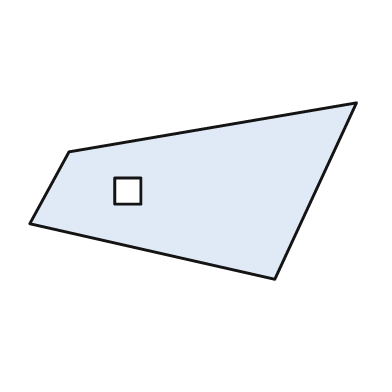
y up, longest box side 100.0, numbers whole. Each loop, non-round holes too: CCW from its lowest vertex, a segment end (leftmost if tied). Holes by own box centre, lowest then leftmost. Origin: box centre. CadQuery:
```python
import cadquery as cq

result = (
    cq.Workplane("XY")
    .moveTo(25.0, -27.0)
    .lineTo(50.0, 27.0)
    .lineTo(-38.0, 12.0)
    .lineTo(-50.0, -10.0)
    .close()
    .moveTo(-24.0, -4.0)
    .lineTo(-16.0, -4.0)
    .lineTo(-16.0, 4.0)
    .lineTo(-24.0, 4.0)
    .close()
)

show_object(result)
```